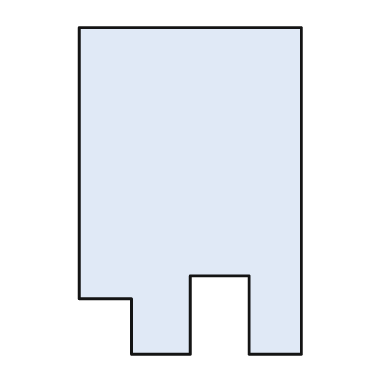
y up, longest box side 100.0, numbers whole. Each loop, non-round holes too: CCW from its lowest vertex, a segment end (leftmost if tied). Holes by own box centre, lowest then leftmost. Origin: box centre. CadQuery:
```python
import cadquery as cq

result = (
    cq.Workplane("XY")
    .moveTo(-18.0, -50.0)
    .lineTo(0.0, -50.0)
    .lineTo(0.0, -26.0)
    .lineTo(18.0, -26.0)
    .lineTo(18.0, -50.0)
    .lineTo(34.0, -50.0)
    .lineTo(34.0, 50.0)
    .lineTo(-34.0, 50.0)
    .lineTo(-34.0, -33.0)
    .lineTo(-18.0, -33.0)
    .close()
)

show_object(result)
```